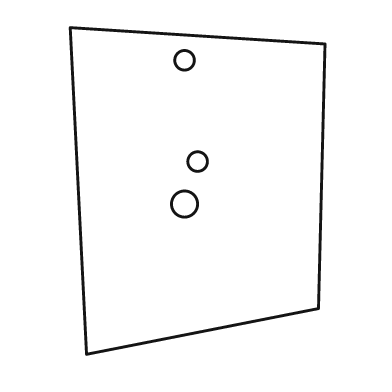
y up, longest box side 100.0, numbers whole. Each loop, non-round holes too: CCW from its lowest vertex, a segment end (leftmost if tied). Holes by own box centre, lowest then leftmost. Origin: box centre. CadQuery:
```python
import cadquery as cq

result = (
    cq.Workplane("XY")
    .moveTo(-34.0, -50.0)
    .lineTo(37.0, -36.0)
    .lineTo(39.0, 45.0)
    .lineTo(-39.0, 50.0)
    .close()
    .moveTo(-4.0, -4.0)
    .circle(4.0)
    .moveTo(0.0, 9.0)
    .circle(3.0)
    .moveTo(-4.0, 40.0)
    .circle(3.0)
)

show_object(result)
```